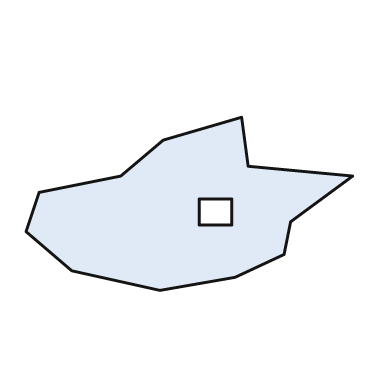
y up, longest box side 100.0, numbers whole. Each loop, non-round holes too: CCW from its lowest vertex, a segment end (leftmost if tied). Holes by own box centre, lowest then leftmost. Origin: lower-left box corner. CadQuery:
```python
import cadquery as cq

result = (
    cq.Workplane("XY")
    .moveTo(41.0, 0.0)
    .lineTo(64.0, 4.0)
    .lineTo(79.0, 11.0)
    .lineTo(81.0, 21.0)
    .lineTo(100.0, 35.0)
    .lineTo(68.0, 38.0)
    .lineTo(66.0, 53.0)
    .lineTo(42.0, 46.0)
    .lineTo(29.0, 35.0)
    .lineTo(4.0, 30.0)
    .lineTo(0.0, 18.0)
    .lineTo(14.0, 6.0)
    .close()
    .moveTo(53.0, 20.0)
    .lineTo(63.0, 20.0)
    .lineTo(63.0, 28.0)
    .lineTo(53.0, 28.0)
    .close()
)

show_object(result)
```